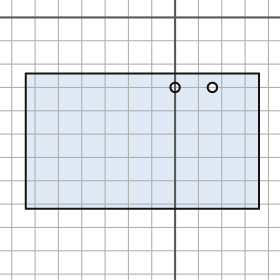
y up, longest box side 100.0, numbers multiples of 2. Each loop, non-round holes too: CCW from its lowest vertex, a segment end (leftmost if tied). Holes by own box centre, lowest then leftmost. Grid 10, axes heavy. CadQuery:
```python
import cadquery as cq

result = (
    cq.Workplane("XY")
    .moveTo(-64.0, -82.0)
    .lineTo(36.0, -82.0)
    .lineTo(36.0, -24.0)
    .lineTo(-64.0, -24.0)
    .close()
    .moveTo(0.0, -30.0)
    .circle(2.0)
    .moveTo(16.0, -30.0)
    .circle(2.0)
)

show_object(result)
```